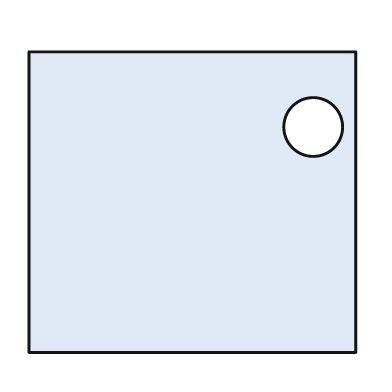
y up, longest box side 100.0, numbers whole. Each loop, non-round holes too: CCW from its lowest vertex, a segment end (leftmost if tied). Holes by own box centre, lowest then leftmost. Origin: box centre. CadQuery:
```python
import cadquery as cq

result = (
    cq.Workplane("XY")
    .moveTo(-50.0, -46.0)
    .lineTo(50.0, -46.0)
    .lineTo(50.0, 46.0)
    .lineTo(-50.0, 46.0)
    .close()
    .moveTo(37.0, 23.0)
    .circle(9.0)
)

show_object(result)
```